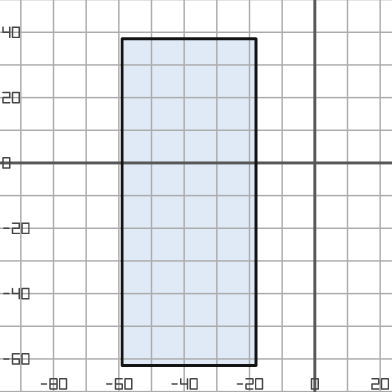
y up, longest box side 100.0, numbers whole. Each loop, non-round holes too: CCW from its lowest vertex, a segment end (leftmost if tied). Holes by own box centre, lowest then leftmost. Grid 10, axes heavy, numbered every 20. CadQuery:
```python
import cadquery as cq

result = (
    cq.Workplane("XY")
    .moveTo(-59.0, -62.0)
    .lineTo(-18.0, -62.0)
    .lineTo(-18.0, 38.0)
    .lineTo(-59.0, 38.0)
    .close()
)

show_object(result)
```